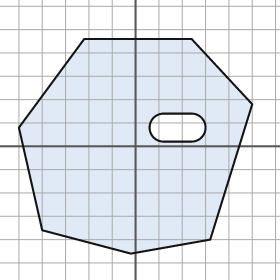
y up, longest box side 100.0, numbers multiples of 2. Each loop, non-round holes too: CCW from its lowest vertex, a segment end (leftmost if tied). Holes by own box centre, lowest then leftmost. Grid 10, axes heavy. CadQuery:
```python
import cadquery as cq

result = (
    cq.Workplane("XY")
    .moveTo(-2.0, -46.0)
    .lineTo(32.0, -40.0)
    .lineTo(50.0, 18.0)
    .lineTo(24.0, 46.0)
    .lineTo(-22.0, 46.0)
    .lineTo(-50.0, 8.0)
    .lineTo(-40.0, -36.0)
    .close()
    .moveTo(12.0, 2.0)
    .lineTo(24.0, 2.0)
    .threePointArc((30.0, 8.0), (24.0, 14.0))
    .lineTo(12.0, 14.0)
    .threePointArc((6.0, 8.0), (12.0, 2.0))
    .close()
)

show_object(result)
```